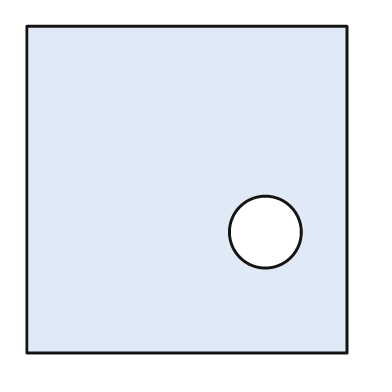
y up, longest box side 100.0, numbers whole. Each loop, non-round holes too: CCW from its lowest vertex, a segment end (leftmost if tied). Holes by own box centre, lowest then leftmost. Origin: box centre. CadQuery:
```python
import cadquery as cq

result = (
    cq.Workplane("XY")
    .moveTo(-49.0, -50.0)
    .lineTo(49.0, -50.0)
    .lineTo(49.0, 50.0)
    .lineTo(-49.0, 50.0)
    .close()
    .moveTo(24.0, -13.0)
    .circle(11.0)
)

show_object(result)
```